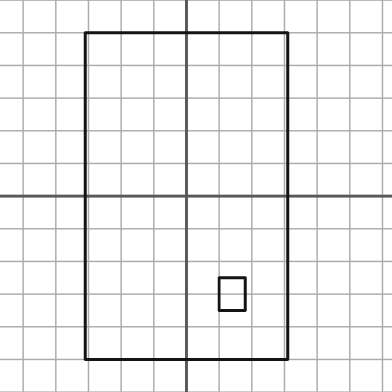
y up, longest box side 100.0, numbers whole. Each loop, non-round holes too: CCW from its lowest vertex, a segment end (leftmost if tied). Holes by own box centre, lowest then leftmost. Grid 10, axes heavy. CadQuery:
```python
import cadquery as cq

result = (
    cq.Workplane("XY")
    .moveTo(-31.0, -50.0)
    .lineTo(31.0, -50.0)
    .lineTo(31.0, 50.0)
    .lineTo(-31.0, 50.0)
    .close()
    .moveTo(10.0, -35.0)
    .lineTo(18.0, -35.0)
    .lineTo(18.0, -25.0)
    .lineTo(10.0, -25.0)
    .close()
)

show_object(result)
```